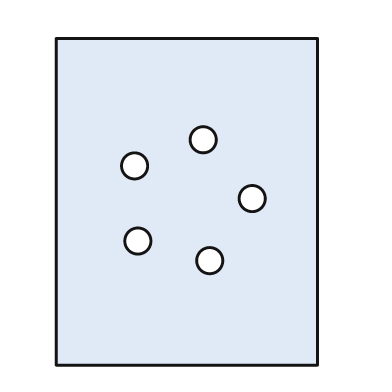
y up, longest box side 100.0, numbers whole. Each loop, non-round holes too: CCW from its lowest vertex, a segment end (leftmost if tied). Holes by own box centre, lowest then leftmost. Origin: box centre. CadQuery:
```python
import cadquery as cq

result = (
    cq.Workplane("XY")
    .moveTo(-40.0, -50.0)
    .lineTo(40.0, -50.0)
    .lineTo(40.0, 50.0)
    .lineTo(-40.0, 50.0)
    .close()
    .moveTo(7.0, -18.0)
    .circle(4.0)
    .moveTo(-15.0, -12.0)
    .circle(4.0)
    .moveTo(20.0, 1.0)
    .circle(4.0)
    .moveTo(-16.0, 11.0)
    .circle(4.0)
    .moveTo(5.0, 19.0)
    .circle(4.0)
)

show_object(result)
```